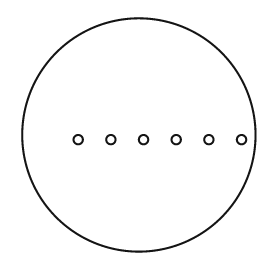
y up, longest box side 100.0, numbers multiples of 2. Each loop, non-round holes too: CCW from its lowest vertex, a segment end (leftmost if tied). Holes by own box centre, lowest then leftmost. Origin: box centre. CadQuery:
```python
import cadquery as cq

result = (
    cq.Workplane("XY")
    .moveTo(0.0, 0.0)
    .circle(50.0)
    .moveTo(-26.0, -2.0)
    .circle(2.0)
    .moveTo(-12.0, -2.0)
    .circle(2.0)
    .moveTo(2.0, -2.0)
    .circle(2.0)
    .moveTo(16.0, -2.0)
    .circle(2.0)
    .moveTo(30.0, -2.0)
    .circle(2.0)
    .moveTo(44.0, -2.0)
    .circle(2.0)
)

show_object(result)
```